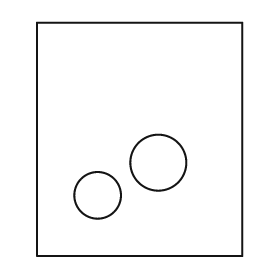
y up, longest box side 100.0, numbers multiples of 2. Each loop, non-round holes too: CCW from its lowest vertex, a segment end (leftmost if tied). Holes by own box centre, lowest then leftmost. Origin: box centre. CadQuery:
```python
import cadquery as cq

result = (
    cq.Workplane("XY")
    .moveTo(-44.0, -50.0)
    .lineTo(44.0, -50.0)
    .lineTo(44.0, 50.0)
    .lineTo(-44.0, 50.0)
    .close()
    .moveTo(-18.0, -24.0)
    .circle(10.0)
    .moveTo(8.0, -10.0)
    .circle(12.0)
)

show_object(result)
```